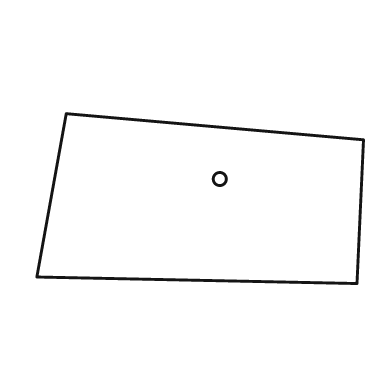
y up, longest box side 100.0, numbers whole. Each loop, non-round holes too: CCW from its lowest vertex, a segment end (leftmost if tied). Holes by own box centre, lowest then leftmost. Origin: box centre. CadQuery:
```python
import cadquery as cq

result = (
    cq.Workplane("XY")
    .moveTo(48.0, -26.0)
    .lineTo(50.0, 18.0)
    .lineTo(-41.0, 26.0)
    .lineTo(-50.0, -24.0)
    .close()
    .moveTo(6.0, 6.0)
    .circle(2.0)
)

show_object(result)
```